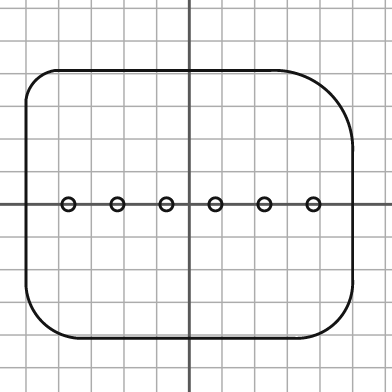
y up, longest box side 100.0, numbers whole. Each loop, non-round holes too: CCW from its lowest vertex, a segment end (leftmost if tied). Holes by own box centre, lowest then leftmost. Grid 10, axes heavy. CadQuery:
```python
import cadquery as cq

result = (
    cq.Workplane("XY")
    .moveTo(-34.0, -41.0)
    .lineTo(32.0, -41.0)
    .threePointArc((45.0, -36.0), (50.0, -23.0))
    .lineTo(50.0, 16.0)
    .threePointArc((43.0, 34.0), (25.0, 41.0))
    .lineTo(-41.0, 41.0)
    .threePointArc((-47.0, 38.0), (-50.0, 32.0))
    .lineTo(-50.0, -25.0)
    .threePointArc((-45.0, -36.0), (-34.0, -41.0))
    .close()
    .moveTo(-37.0, 0.0)
    .circle(2.0)
    .moveTo(-22.0, 0.0)
    .circle(2.0)
    .moveTo(-7.0, 0.0)
    .circle(2.0)
    .moveTo(8.0, 0.0)
    .circle(2.0)
    .moveTo(23.0, 0.0)
    .circle(2.0)
    .moveTo(38.0, 0.0)
    .circle(2.0)
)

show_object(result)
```